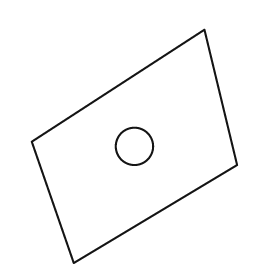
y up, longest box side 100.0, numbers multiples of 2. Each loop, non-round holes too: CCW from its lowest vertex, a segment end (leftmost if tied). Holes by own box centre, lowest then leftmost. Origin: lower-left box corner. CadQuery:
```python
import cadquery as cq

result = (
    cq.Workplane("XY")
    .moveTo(18.0, 0.0)
    .lineTo(88.0, 42.0)
    .lineTo(74.0, 100.0)
    .lineTo(0.0, 52.0)
    .close()
    .moveTo(44.0, 50.0)
    .circle(8.0)
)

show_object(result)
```